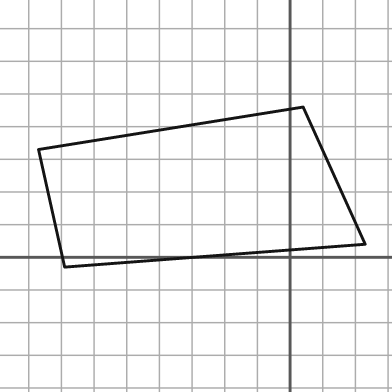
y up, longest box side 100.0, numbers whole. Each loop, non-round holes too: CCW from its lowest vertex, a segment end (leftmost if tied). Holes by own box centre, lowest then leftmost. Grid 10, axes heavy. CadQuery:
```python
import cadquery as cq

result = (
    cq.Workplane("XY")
    .moveTo(-69.0, -3.0)
    .lineTo(23.0, 4.0)
    .lineTo(4.0, 46.0)
    .lineTo(-77.0, 33.0)
    .close()
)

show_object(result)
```